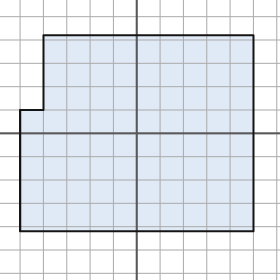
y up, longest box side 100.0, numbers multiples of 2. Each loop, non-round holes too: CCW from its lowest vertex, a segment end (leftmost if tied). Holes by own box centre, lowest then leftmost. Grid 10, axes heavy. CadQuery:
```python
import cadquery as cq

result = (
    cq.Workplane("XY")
    .moveTo(-50.0, -42.0)
    .lineTo(50.0, -42.0)
    .lineTo(50.0, 42.0)
    .lineTo(-40.0, 42.0)
    .lineTo(-40.0, 10.0)
    .lineTo(-50.0, 10.0)
    .close()
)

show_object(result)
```